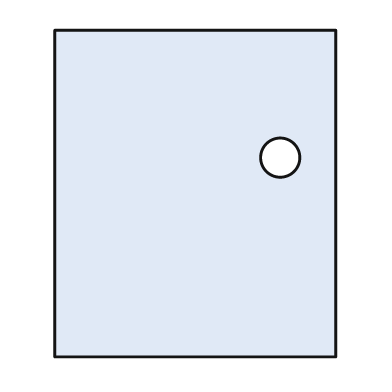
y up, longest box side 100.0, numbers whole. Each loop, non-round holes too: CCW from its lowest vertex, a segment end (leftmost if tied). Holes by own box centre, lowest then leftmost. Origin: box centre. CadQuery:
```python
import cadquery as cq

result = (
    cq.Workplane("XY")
    .moveTo(-43.0, -50.0)
    .lineTo(43.0, -50.0)
    .lineTo(43.0, 50.0)
    .lineTo(-43.0, 50.0)
    .close()
    .moveTo(26.0, 11.0)
    .circle(6.0)
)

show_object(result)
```